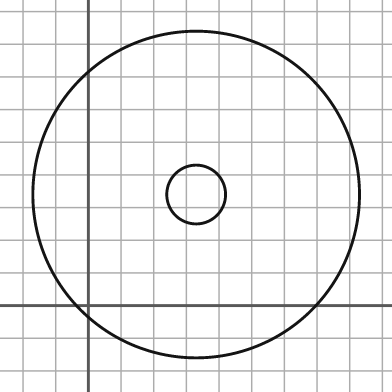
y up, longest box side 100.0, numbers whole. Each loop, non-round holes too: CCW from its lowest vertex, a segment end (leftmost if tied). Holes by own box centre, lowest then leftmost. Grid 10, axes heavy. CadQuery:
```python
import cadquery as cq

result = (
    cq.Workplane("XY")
    .moveTo(33.0, 34.0)
    .circle(50.0)
    .moveTo(33.0, 34.0)
    .circle(9.0)
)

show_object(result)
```